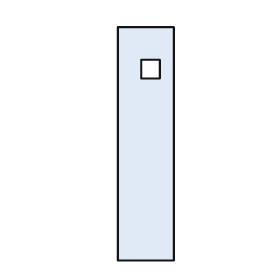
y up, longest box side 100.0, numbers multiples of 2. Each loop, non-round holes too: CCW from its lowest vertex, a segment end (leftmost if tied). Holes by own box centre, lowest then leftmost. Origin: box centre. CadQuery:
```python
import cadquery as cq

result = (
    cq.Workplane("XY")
    .moveTo(-12.0, -50.0)
    .lineTo(12.0, -50.0)
    .lineTo(12.0, 50.0)
    .lineTo(-12.0, 50.0)
    .close()
    .moveTo(-2.0, 28.0)
    .lineTo(6.0, 28.0)
    .lineTo(6.0, 36.0)
    .lineTo(-2.0, 36.0)
    .close()
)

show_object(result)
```